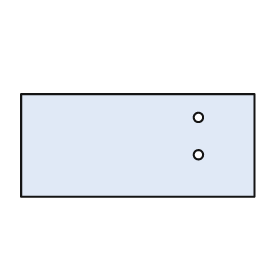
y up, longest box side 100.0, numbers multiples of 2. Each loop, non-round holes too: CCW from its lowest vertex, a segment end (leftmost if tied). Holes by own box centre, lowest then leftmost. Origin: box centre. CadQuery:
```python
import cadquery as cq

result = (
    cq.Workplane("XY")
    .moveTo(-50.0, -22.0)
    .lineTo(50.0, -22.0)
    .lineTo(50.0, 22.0)
    .lineTo(-50.0, 22.0)
    .close()
    .moveTo(26.0, -4.0)
    .circle(2.0)
    .moveTo(26.0, 12.0)
    .circle(2.0)
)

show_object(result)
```